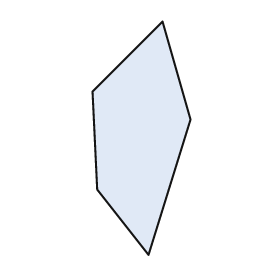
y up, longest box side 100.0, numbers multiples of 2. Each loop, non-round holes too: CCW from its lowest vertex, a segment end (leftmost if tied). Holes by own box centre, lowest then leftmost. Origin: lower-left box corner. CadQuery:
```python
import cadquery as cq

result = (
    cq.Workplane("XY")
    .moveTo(24.0, 0.0)
    .lineTo(42.0, 58.0)
    .lineTo(30.0, 100.0)
    .lineTo(0.0, 70.0)
    .lineTo(2.0, 28.0)
    .close()
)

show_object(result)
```